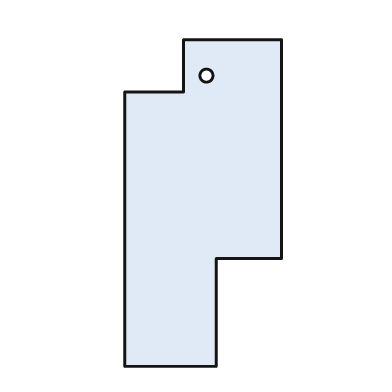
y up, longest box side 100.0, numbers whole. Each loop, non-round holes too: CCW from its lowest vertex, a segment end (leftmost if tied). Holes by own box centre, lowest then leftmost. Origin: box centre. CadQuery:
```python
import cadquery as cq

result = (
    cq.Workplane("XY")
    .moveTo(-24.0, -50.0)
    .lineTo(4.0, -50.0)
    .lineTo(4.0, -17.0)
    .lineTo(24.0, -17.0)
    .lineTo(24.0, 50.0)
    .lineTo(-6.0, 50.0)
    .lineTo(-6.0, 34.0)
    .lineTo(-24.0, 34.0)
    .close()
    .moveTo(1.0, 39.0)
    .circle(2.0)
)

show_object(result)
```